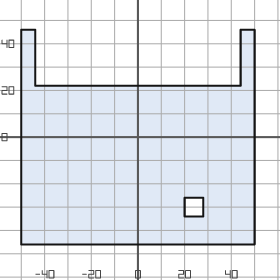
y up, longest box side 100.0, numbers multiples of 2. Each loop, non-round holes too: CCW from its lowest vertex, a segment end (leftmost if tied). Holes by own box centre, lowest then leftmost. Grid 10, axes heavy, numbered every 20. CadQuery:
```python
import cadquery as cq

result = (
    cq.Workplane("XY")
    .moveTo(-50.0, -46.0)
    .lineTo(50.0, -46.0)
    .lineTo(50.0, 46.0)
    .lineTo(44.0, 46.0)
    .lineTo(44.0, 22.0)
    .lineTo(-44.0, 22.0)
    .lineTo(-44.0, 46.0)
    .lineTo(-50.0, 46.0)
    .close()
    .moveTo(20.0, -34.0)
    .lineTo(28.0, -34.0)
    .lineTo(28.0, -26.0)
    .lineTo(20.0, -26.0)
    .close()
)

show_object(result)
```